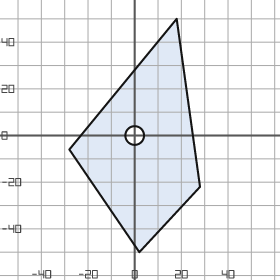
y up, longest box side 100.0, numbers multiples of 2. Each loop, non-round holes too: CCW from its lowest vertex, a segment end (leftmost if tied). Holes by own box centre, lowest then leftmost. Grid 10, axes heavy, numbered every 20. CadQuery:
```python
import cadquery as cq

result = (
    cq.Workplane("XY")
    .moveTo(2.0, -50.0)
    .lineTo(28.0, -22.0)
    .lineTo(18.0, 50.0)
    .lineTo(-28.0, -6.0)
    .close()
    .moveTo(0.0, 0.0)
    .circle(4.0)
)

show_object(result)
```